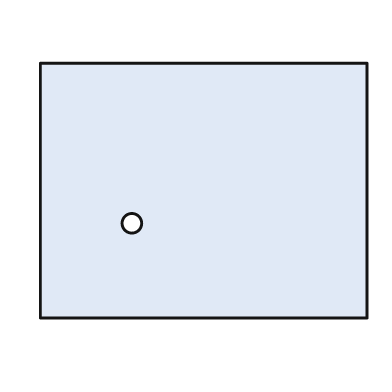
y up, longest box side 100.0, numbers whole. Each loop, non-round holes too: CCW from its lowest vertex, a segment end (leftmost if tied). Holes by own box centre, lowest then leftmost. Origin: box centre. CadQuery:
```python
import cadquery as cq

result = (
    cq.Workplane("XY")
    .moveTo(-50.0, -39.0)
    .lineTo(50.0, -39.0)
    .lineTo(50.0, 39.0)
    .lineTo(-50.0, 39.0)
    .close()
    .moveTo(-22.0, -10.0)
    .circle(3.0)
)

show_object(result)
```